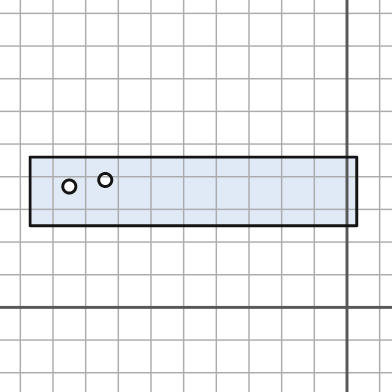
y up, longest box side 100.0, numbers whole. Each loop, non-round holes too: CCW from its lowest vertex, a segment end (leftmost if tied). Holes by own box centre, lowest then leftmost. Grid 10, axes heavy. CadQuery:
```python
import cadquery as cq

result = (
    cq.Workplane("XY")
    .moveTo(-97.0, 25.0)
    .lineTo(3.0, 25.0)
    .lineTo(3.0, 46.0)
    .lineTo(-97.0, 46.0)
    .close()
    .moveTo(-85.0, 37.0)
    .circle(2.0)
    .moveTo(-74.0, 39.0)
    .circle(2.0)
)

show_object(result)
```